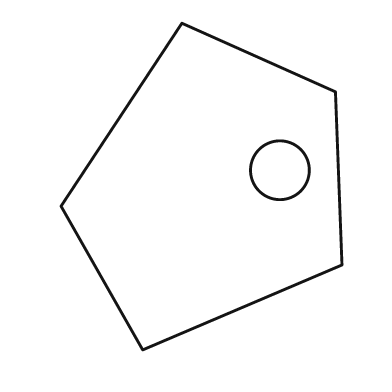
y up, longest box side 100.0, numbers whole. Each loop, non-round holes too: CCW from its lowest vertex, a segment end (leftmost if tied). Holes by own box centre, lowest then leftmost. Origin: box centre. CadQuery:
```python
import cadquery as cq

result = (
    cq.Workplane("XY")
    .moveTo(-18.0, -50.0)
    .lineTo(43.0, -24.0)
    .lineTo(41.0, 29.0)
    .lineTo(-6.0, 50.0)
    .lineTo(-43.0, -6.0)
    .close()
    .moveTo(24.0, 5.0)
    .circle(9.0)
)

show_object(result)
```